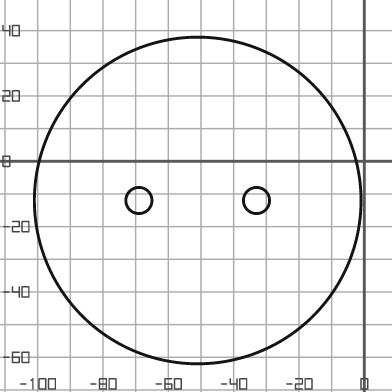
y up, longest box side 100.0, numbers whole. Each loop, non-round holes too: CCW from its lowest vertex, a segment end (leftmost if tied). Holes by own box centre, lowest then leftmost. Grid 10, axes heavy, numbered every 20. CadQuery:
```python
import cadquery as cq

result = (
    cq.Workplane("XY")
    .moveTo(-51.0, -12.0)
    .circle(50.0)
    .moveTo(-69.0, -12.0)
    .circle(4.0)
    .moveTo(-33.0, -12.0)
    .circle(4.0)
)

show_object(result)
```